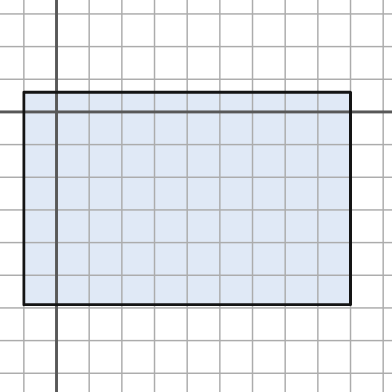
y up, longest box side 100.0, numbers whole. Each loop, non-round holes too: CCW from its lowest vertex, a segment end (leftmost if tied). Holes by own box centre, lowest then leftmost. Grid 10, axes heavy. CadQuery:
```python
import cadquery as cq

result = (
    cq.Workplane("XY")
    .moveTo(-10.0, -59.0)
    .lineTo(90.0, -59.0)
    .lineTo(90.0, 6.0)
    .lineTo(-10.0, 6.0)
    .close()
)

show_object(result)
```